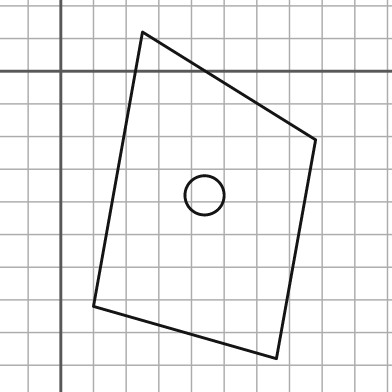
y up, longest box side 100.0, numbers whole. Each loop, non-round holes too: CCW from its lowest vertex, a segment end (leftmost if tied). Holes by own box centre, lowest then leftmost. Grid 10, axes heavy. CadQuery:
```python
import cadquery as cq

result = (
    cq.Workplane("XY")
    .moveTo(66.0, -88.0)
    .lineTo(78.0, -21.0)
    .lineTo(25.0, 12.0)
    .lineTo(10.0, -72.0)
    .close()
    .moveTo(44.0, -38.0)
    .circle(6.0)
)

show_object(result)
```